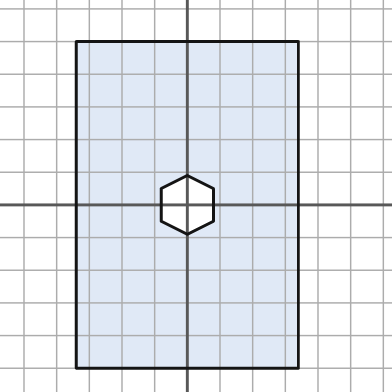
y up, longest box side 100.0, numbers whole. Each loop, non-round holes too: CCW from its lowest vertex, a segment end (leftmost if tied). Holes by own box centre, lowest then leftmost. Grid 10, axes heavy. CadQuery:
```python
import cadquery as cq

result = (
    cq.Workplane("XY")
    .moveTo(-34.0, -50.0)
    .lineTo(34.0, -50.0)
    .lineTo(34.0, 50.0)
    .lineTo(-34.0, 50.0)
    .close()
    .moveTo(0.0, -9.0)
    .lineTo(8.0, -5.0)
    .lineTo(8.0, 5.0)
    .lineTo(0.0, 9.0)
    .lineTo(-8.0, 5.0)
    .lineTo(-8.0, -5.0)
    .close()
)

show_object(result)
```